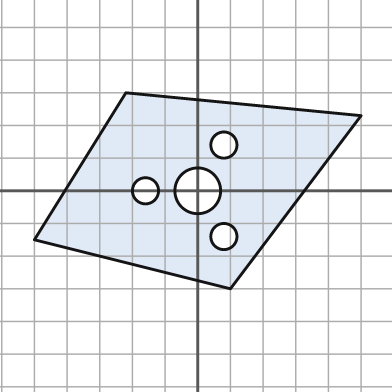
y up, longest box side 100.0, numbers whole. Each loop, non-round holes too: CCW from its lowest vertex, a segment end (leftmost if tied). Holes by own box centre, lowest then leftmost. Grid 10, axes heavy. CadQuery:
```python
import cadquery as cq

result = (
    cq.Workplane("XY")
    .moveTo(10.0, -30.0)
    .lineTo(50.0, 23.0)
    .lineTo(-22.0, 30.0)
    .lineTo(-50.0, -15.0)
    .close()
    .moveTo(8.0, -14.0)
    .circle(4.0)
    .moveTo(-16.0, 0.0)
    .circle(4.0)
    .moveTo(0.0, 0.0)
    .circle(7.0)
    .moveTo(8.0, 14.0)
    .circle(4.0)
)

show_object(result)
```